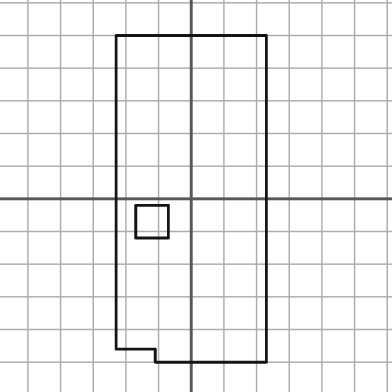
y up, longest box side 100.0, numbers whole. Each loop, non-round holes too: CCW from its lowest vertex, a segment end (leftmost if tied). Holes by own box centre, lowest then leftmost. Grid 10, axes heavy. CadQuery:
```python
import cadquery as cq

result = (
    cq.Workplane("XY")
    .moveTo(-11.0, -50.0)
    .lineTo(23.0, -50.0)
    .lineTo(23.0, 50.0)
    .lineTo(-23.0, 50.0)
    .lineTo(-23.0, -46.0)
    .lineTo(-11.0, -46.0)
    .close()
    .moveTo(-17.0, -12.0)
    .lineTo(-7.0, -12.0)
    .lineTo(-7.0, -2.0)
    .lineTo(-17.0, -2.0)
    .close()
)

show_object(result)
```